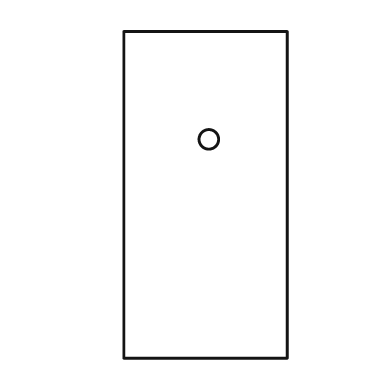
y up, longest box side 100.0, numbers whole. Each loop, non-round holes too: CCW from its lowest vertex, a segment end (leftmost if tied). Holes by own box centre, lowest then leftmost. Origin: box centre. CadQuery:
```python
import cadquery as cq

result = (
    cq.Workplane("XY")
    .moveTo(-25.0, -50.0)
    .lineTo(25.0, -50.0)
    .lineTo(25.0, 50.0)
    .lineTo(-25.0, 50.0)
    .close()
    .moveTo(1.0, 17.0)
    .circle(3.0)
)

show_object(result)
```